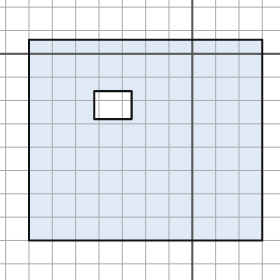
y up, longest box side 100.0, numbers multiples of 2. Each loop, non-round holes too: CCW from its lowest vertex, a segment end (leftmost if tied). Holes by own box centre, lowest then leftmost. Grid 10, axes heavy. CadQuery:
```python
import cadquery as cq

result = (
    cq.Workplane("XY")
    .moveTo(-70.0, -80.0)
    .lineTo(30.0, -80.0)
    .lineTo(30.0, 6.0)
    .lineTo(-70.0, 6.0)
    .close()
    .moveTo(-42.0, -28.0)
    .lineTo(-26.0, -28.0)
    .lineTo(-26.0, -16.0)
    .lineTo(-42.0, -16.0)
    .close()
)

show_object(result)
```